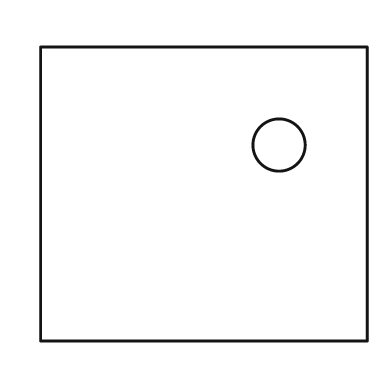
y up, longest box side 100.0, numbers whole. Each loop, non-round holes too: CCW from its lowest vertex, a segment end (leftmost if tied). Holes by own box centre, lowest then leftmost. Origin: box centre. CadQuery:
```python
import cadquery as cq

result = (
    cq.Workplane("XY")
    .moveTo(-50.0, -45.0)
    .lineTo(50.0, -45.0)
    .lineTo(50.0, 45.0)
    .lineTo(-50.0, 45.0)
    .close()
    .moveTo(23.0, 15.0)
    .circle(8.0)
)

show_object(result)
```